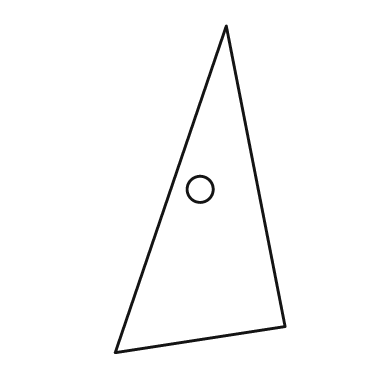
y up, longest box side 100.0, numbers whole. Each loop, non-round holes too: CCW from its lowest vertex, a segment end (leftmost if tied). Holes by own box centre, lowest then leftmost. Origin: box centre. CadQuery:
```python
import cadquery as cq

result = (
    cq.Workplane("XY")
    .moveTo(-26.0, -50.0)
    .lineTo(26.0, -42.0)
    .lineTo(8.0, 50.0)
    .close()
    .moveTo(0.0, 0.0)
    .circle(4.0)
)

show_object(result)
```